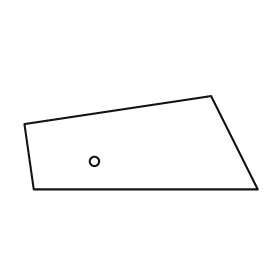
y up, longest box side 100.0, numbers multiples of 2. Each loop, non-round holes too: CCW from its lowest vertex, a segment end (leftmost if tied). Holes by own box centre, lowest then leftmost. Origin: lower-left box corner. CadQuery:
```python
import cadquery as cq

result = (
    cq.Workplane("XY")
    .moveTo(4.0, 0.0)
    .lineTo(100.0, 0.0)
    .lineTo(80.0, 40.0)
    .lineTo(0.0, 28.0)
    .close()
    .moveTo(30.0, 12.0)
    .circle(2.0)
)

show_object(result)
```